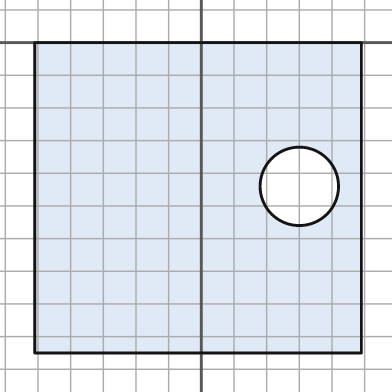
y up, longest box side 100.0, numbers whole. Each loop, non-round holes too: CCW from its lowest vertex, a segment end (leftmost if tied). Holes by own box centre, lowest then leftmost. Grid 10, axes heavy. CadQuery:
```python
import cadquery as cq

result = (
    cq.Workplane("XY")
    .moveTo(-51.0, -95.0)
    .lineTo(49.0, -95.0)
    .lineTo(49.0, 0.0)
    .lineTo(-51.0, 0.0)
    .close()
    .moveTo(30.0, -44.0)
    .circle(12.0)
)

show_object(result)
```